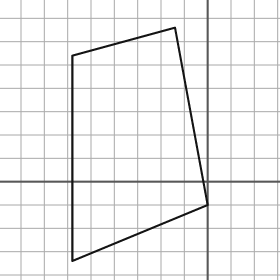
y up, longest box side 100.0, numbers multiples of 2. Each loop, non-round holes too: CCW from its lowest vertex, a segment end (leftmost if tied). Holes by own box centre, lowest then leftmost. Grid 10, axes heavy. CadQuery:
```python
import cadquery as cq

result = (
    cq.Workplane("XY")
    .moveTo(-58.0, -34.0)
    .lineTo(0.0, -10.0)
    .lineTo(-14.0, 66.0)
    .lineTo(-58.0, 54.0)
    .close()
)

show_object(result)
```